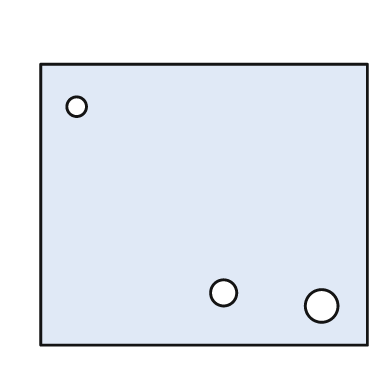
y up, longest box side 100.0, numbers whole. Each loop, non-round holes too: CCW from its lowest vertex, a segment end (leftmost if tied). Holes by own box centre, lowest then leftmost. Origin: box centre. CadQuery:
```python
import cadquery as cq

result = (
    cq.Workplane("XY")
    .moveTo(-50.0, -43.0)
    .lineTo(50.0, -43.0)
    .lineTo(50.0, 43.0)
    .lineTo(-50.0, 43.0)
    .close()
    .moveTo(36.0, -31.0)
    .circle(5.0)
    .moveTo(6.0, -27.0)
    .circle(4.0)
    .moveTo(-39.0, 30.0)
    .circle(3.0)
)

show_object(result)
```